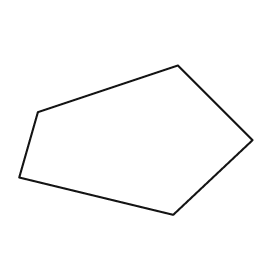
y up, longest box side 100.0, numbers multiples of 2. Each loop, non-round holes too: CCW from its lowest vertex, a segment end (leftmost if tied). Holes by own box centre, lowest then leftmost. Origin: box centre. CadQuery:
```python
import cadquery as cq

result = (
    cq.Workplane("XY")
    .moveTo(16.0, -32.0)
    .lineTo(50.0, 0.0)
    .lineTo(18.0, 32.0)
    .lineTo(-42.0, 12.0)
    .lineTo(-50.0, -16.0)
    .close()
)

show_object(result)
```